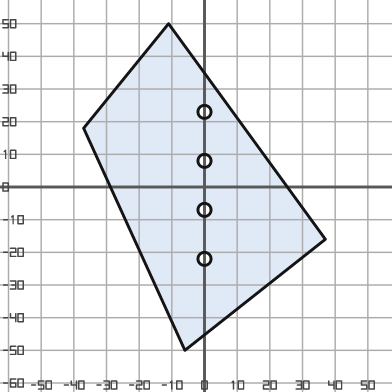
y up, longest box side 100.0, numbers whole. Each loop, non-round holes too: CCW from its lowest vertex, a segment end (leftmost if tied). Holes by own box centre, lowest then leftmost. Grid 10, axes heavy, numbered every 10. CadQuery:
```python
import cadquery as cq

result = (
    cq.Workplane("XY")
    .moveTo(-6.0, -50.0)
    .lineTo(37.0, -16.0)
    .lineTo(-11.0, 50.0)
    .lineTo(-37.0, 18.0)
    .close()
    .moveTo(0.0, -22.0)
    .circle(2.0)
    .moveTo(0.0, -7.0)
    .circle(2.0)
    .moveTo(0.0, 8.0)
    .circle(2.0)
    .moveTo(0.0, 23.0)
    .circle(2.0)
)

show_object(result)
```